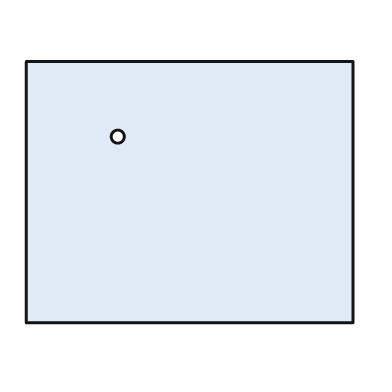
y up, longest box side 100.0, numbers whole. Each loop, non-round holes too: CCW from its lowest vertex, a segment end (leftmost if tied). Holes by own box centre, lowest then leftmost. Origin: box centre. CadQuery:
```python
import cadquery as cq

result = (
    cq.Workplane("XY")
    .moveTo(-50.0, -40.0)
    .lineTo(50.0, -40.0)
    .lineTo(50.0, 40.0)
    .lineTo(-50.0, 40.0)
    .close()
    .moveTo(-22.0, 17.0)
    .circle(2.0)
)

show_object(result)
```